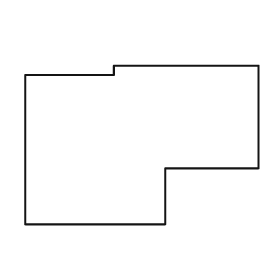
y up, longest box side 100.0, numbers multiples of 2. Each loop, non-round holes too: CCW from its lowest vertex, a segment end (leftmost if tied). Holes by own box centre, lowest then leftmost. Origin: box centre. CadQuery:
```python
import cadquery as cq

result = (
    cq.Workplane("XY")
    .moveTo(-50.0, -34.0)
    .lineTo(10.0, -34.0)
    .lineTo(10.0, -10.0)
    .lineTo(50.0, -10.0)
    .lineTo(50.0, 34.0)
    .lineTo(-12.0, 34.0)
    .lineTo(-12.0, 30.0)
    .lineTo(-50.0, 30.0)
    .close()
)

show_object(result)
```